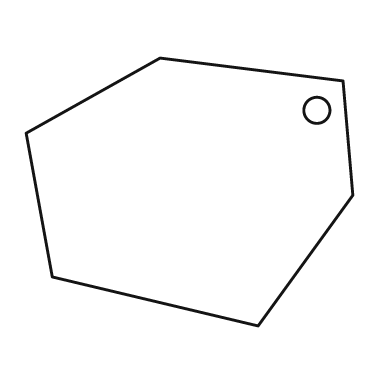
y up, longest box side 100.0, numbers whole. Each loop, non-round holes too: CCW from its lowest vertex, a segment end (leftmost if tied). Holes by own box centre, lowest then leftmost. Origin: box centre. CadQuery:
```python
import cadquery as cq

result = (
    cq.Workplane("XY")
    .moveTo(21.0, -41.0)
    .lineTo(50.0, -1.0)
    .lineTo(47.0, 34.0)
    .lineTo(-9.0, 41.0)
    .lineTo(-50.0, 18.0)
    .lineTo(-42.0, -26.0)
    .close()
    .moveTo(39.0, 25.0)
    .circle(4.0)
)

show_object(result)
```